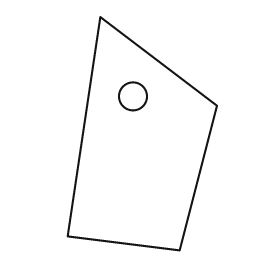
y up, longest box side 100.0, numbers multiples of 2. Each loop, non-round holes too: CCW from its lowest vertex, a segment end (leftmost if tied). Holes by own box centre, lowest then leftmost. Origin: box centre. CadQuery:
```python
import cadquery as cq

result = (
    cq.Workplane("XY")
    .moveTo(16.0, -50.0)
    .lineTo(32.0, 12.0)
    .lineTo(-18.0, 50.0)
    .lineTo(-32.0, -44.0)
    .close()
    .moveTo(-4.0, 16.0)
    .circle(6.0)
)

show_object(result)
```